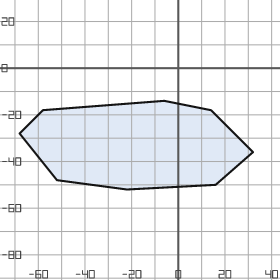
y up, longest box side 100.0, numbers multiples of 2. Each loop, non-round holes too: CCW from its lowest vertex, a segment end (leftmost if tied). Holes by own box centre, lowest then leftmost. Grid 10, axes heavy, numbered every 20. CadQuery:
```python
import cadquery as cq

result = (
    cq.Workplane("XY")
    .moveTo(-22.0, -52.0)
    .lineTo(16.0, -50.0)
    .lineTo(32.0, -36.0)
    .lineTo(14.0, -18.0)
    .lineTo(-6.0, -14.0)
    .lineTo(-58.0, -18.0)
    .lineTo(-68.0, -28.0)
    .lineTo(-52.0, -48.0)
    .close()
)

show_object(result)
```